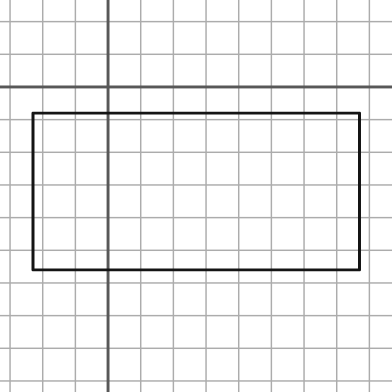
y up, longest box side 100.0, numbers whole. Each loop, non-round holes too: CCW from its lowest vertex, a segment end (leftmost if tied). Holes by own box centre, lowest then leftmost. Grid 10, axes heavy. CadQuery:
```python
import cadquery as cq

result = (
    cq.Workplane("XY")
    .moveTo(-23.0, -56.0)
    .lineTo(77.0, -56.0)
    .lineTo(77.0, -8.0)
    .lineTo(-23.0, -8.0)
    .close()
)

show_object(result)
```